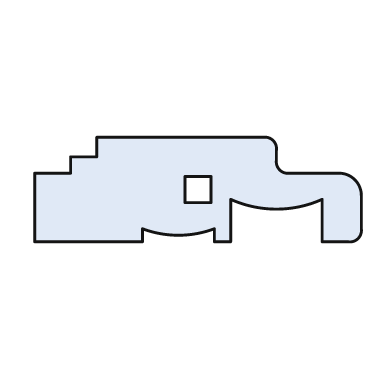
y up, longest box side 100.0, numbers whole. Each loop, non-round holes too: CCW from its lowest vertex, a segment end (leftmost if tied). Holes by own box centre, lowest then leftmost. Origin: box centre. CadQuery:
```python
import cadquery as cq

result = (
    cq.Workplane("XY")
    .moveTo(-50.0, -16.0)
    .lineTo(-17.0, -16.0)
    .lineTo(-17.0, -12.0)
    .threePointArc((-6.0, -14.0), (5.0, -12.0))
    .lineTo(5.0, -16.0)
    .lineTo(10.0, -16.0)
    .lineTo(10.0, -3.0)
    .threePointArc((24.0, -6.0), (38.0, -3.0))
    .lineTo(38.0, -16.0)
    .lineTo(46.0, -16.0)
    .threePointArc((49.0, -15.0), (50.0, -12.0))
    .lineTo(50.0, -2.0)
    .threePointArc((48.0, 3.0), (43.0, 5.0))
    .lineTo(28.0, 5.0)
    .threePointArc((25.0, 6.0), (24.0, 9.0))
    .lineTo(24.0, 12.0)
    .threePointArc((23.0, 15.0), (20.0, 16.0))
    .lineTo(-31.0, 16.0)
    .lineTo(-31.0, 10.0)
    .lineTo(-39.0, 10.0)
    .lineTo(-39.0, 5.0)
    .lineTo(-50.0, 5.0)
    .close()
    .moveTo(-4.0, -4.0)
    .lineTo(4.0, -4.0)
    .lineTo(4.0, 4.0)
    .lineTo(-4.0, 4.0)
    .close()
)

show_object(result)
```